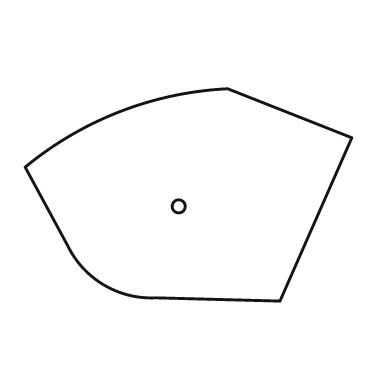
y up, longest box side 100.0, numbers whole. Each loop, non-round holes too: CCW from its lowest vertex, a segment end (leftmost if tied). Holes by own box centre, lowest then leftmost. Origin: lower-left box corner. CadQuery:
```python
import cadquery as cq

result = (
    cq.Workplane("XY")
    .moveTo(78.0, 0.0)
    .lineTo(100.0, 50.0)
    .lineTo(62.0, 65.0)
    .threePointArc((29.0, 58.0), (0.0, 41.0))
    .lineTo(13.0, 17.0)
    .threePointArc((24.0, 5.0), (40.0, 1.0))
    .close()
    .moveTo(47.0, 29.0)
    .circle(2.0)
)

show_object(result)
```